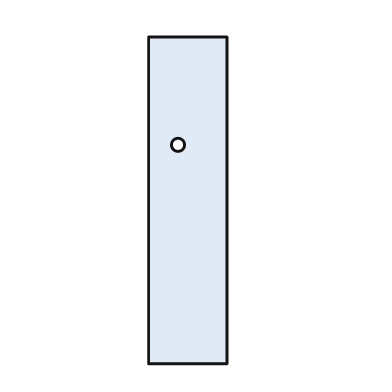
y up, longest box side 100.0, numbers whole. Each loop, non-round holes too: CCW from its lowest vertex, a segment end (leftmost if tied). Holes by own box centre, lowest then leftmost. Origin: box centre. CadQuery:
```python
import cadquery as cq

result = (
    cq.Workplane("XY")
    .moveTo(-12.0, -50.0)
    .lineTo(12.0, -50.0)
    .lineTo(12.0, 50.0)
    .lineTo(-12.0, 50.0)
    .close()
    .moveTo(-3.0, 17.0)
    .circle(2.0)
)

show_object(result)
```